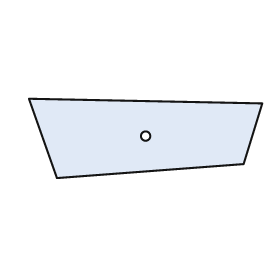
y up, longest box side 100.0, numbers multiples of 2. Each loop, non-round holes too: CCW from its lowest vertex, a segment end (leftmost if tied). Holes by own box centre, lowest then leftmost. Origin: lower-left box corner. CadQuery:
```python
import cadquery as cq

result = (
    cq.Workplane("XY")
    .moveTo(12.0, 0.0)
    .lineTo(92.0, 6.0)
    .lineTo(100.0, 32.0)
    .lineTo(0.0, 34.0)
    .close()
    .moveTo(50.0, 18.0)
    .circle(2.0)
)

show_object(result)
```